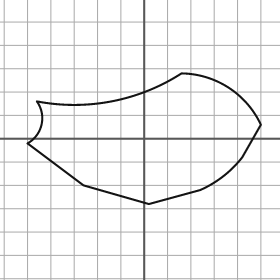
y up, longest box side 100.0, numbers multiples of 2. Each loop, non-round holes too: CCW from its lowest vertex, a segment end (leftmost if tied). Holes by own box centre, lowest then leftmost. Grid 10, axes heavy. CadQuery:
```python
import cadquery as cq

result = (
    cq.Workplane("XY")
    .moveTo(2.0, -28.0)
    .lineTo(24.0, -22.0)
    .threePointArc((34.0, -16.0), (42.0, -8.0))
    .lineTo(50.0, 6.0)
    .threePointArc((36.0, 22.0), (16.0, 28.0))
    .threePointArc((-14.0, 16.0), (-46.0, 16.0))
    .threePointArc((-44.0, 6.0), (-50.0, -2.0))
    .lineTo(-26.0, -20.0)
    .close()
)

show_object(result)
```